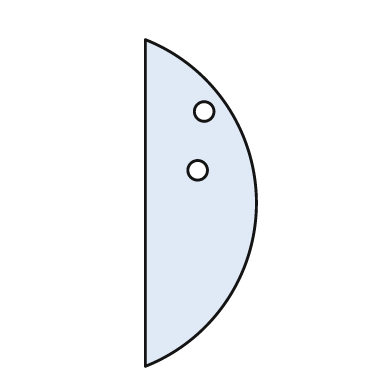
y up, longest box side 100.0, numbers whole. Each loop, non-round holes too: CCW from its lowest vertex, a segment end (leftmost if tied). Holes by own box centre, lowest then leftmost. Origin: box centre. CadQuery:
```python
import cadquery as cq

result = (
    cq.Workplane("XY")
    .moveTo(-17.0, -50.0)
    .threePointArc((17.0, 0.0), (-17.0, 50.0))
    .close()
    .moveTo(-1.0, 10.0)
    .circle(3.0)
    .moveTo(1.0, 28.0)
    .circle(3.0)
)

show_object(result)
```